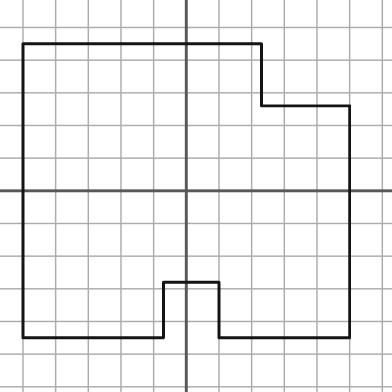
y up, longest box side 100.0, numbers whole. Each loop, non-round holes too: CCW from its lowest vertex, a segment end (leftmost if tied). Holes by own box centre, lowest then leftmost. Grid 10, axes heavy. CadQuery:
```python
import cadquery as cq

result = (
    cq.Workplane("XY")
    .moveTo(-50.0, -45.0)
    .lineTo(-7.0, -45.0)
    .lineTo(-7.0, -28.0)
    .lineTo(10.0, -28.0)
    .lineTo(10.0, -45.0)
    .lineTo(50.0, -45.0)
    .lineTo(50.0, 26.0)
    .lineTo(23.0, 26.0)
    .lineTo(23.0, 45.0)
    .lineTo(-50.0, 45.0)
    .close()
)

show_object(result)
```